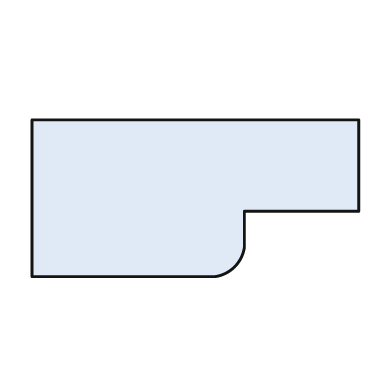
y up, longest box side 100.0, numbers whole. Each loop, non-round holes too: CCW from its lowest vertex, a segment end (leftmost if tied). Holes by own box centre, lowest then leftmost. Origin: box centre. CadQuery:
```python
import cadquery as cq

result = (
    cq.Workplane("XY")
    .moveTo(-50.0, -24.0)
    .lineTo(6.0, -24.0)
    .threePointArc((12.0, -21.0), (15.0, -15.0))
    .lineTo(15.0, -4.0)
    .lineTo(50.0, -4.0)
    .lineTo(50.0, 24.0)
    .lineTo(-50.0, 24.0)
    .close()
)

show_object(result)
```